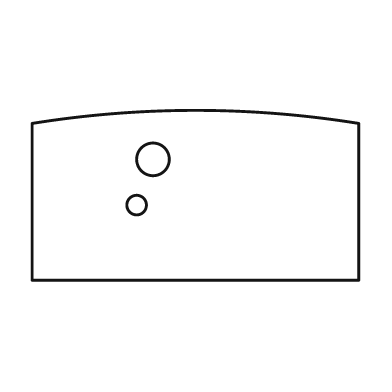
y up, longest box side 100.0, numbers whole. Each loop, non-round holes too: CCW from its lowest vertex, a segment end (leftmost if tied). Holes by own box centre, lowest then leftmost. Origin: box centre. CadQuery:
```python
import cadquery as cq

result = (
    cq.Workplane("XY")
    .moveTo(-50.0, -26.0)
    .lineTo(50.0, -26.0)
    .lineTo(50.0, 22.0)
    .threePointArc((0.0, 26.0), (-50.0, 22.0))
    .close()
    .moveTo(-18.0, -3.0)
    .circle(3.0)
    .moveTo(-13.0, 11.0)
    .circle(5.0)
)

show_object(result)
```